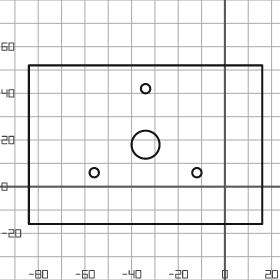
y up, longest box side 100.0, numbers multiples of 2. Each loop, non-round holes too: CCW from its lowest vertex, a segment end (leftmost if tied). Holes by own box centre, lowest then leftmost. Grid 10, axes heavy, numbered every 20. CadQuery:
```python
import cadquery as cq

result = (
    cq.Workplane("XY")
    .moveTo(-84.0, -16.0)
    .lineTo(16.0, -16.0)
    .lineTo(16.0, 52.0)
    .lineTo(-84.0, 52.0)
    .close()
    .moveTo(-56.0, 6.0)
    .circle(2.0)
    .moveTo(-12.0, 6.0)
    .circle(2.0)
    .moveTo(-34.0, 18.0)
    .circle(6.0)
    .moveTo(-34.0, 42.0)
    .circle(2.0)
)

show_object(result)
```